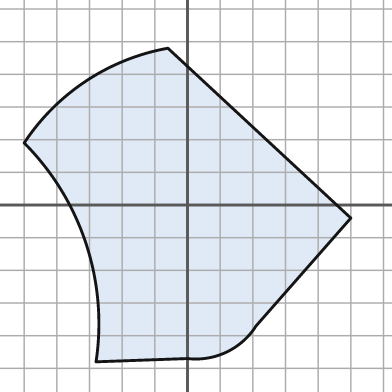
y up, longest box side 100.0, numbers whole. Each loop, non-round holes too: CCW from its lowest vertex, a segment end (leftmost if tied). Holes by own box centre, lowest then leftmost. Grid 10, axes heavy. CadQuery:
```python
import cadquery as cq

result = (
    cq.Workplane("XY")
    .moveTo(-28.0, -48.0)
    .lineTo(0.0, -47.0)
    .threePointArc((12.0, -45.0), (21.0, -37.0))
    .lineTo(50.0, -4.0)
    .lineTo(-6.0, 48.0)
    .threePointArc((-31.0, 38.0), (-50.0, 19.0))
    .threePointArc((-31.0, -12.0), (-28.0, -48.0))
    .close()
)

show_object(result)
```